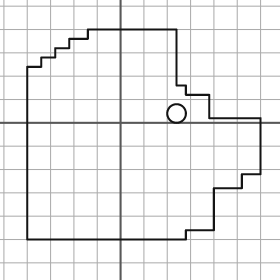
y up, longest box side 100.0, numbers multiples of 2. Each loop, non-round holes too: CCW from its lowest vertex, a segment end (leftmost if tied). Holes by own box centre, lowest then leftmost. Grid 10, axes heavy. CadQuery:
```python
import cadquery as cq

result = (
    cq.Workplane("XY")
    .moveTo(-40.0, -50.0)
    .lineTo(28.0, -50.0)
    .lineTo(28.0, -46.0)
    .lineTo(40.0, -46.0)
    .lineTo(40.0, -28.0)
    .lineTo(52.0, -28.0)
    .lineTo(52.0, -22.0)
    .lineTo(60.0, -22.0)
    .lineTo(60.0, 2.0)
    .lineTo(38.0, 2.0)
    .lineTo(38.0, 12.0)
    .lineTo(28.0, 12.0)
    .lineTo(28.0, 16.0)
    .lineTo(24.0, 16.0)
    .lineTo(24.0, 40.0)
    .lineTo(-14.0, 40.0)
    .lineTo(-14.0, 36.0)
    .lineTo(-22.0, 36.0)
    .lineTo(-22.0, 32.0)
    .lineTo(-28.0, 32.0)
    .lineTo(-28.0, 28.0)
    .lineTo(-34.0, 28.0)
    .lineTo(-34.0, 24.0)
    .lineTo(-40.0, 24.0)
    .close()
    .moveTo(24.0, 4.0)
    .circle(4.0)
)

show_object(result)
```